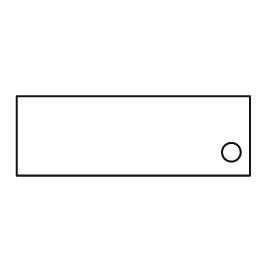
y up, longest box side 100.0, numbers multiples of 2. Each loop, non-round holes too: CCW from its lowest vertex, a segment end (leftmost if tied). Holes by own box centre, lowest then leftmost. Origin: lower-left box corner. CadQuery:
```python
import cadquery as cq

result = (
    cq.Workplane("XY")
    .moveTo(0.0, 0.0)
    .lineTo(100.0, 0.0)
    .lineTo(100.0, 34.0)
    .lineTo(0.0, 34.0)
    .close()
    .moveTo(92.0, 10.0)
    .circle(4.0)
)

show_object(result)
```